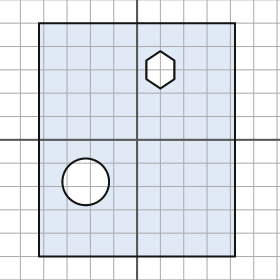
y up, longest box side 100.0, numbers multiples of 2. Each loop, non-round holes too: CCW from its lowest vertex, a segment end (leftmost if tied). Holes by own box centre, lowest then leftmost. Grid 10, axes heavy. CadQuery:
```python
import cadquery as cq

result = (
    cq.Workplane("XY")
    .moveTo(-42.0, -50.0)
    .lineTo(42.0, -50.0)
    .lineTo(42.0, 50.0)
    .lineTo(-42.0, 50.0)
    .close()
    .moveTo(-22.0, -18.0)
    .circle(10.0)
    .moveTo(10.0, 22.0)
    .lineTo(16.0, 26.0)
    .lineTo(16.0, 34.0)
    .lineTo(10.0, 38.0)
    .lineTo(4.0, 34.0)
    .lineTo(4.0, 26.0)
    .close()
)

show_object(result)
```